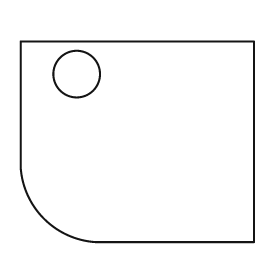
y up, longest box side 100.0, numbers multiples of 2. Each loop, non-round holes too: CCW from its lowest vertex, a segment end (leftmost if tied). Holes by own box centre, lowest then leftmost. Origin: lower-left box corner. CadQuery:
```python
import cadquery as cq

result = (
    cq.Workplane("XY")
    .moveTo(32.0, 0.0)
    .lineTo(100.0, 0.0)
    .lineTo(100.0, 86.0)
    .lineTo(0.0, 86.0)
    .lineTo(0.0, 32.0)
    .threePointArc((10.0, 10.0), (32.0, 0.0))
    .close()
    .moveTo(24.0, 72.0)
    .circle(10.0)
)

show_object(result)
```